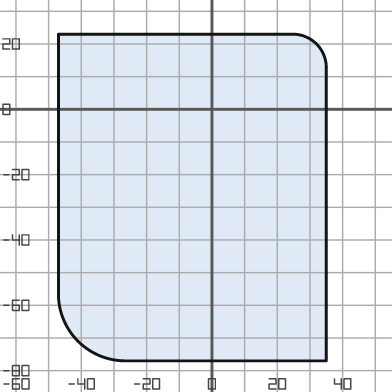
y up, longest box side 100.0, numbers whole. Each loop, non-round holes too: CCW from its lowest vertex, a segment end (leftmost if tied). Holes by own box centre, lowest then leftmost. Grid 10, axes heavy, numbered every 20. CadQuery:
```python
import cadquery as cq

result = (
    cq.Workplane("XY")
    .moveTo(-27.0, -77.0)
    .lineTo(35.0, -77.0)
    .lineTo(35.0, 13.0)
    .threePointArc((32.0, 20.0), (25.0, 23.0))
    .lineTo(-47.0, 23.0)
    .lineTo(-47.0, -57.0)
    .threePointArc((-41.0, -71.0), (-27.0, -77.0))
    .close()
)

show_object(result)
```